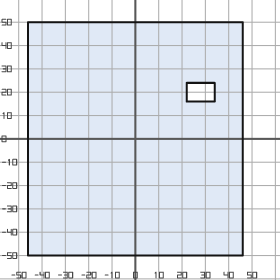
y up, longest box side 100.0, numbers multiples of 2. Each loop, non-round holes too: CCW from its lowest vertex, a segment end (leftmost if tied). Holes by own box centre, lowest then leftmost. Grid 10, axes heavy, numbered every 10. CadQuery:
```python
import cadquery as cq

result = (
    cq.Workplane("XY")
    .moveTo(-46.0, -50.0)
    .lineTo(46.0, -50.0)
    .lineTo(46.0, 50.0)
    .lineTo(-46.0, 50.0)
    .close()
    .moveTo(22.0, 16.0)
    .lineTo(34.0, 16.0)
    .lineTo(34.0, 24.0)
    .lineTo(22.0, 24.0)
    .close()
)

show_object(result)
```